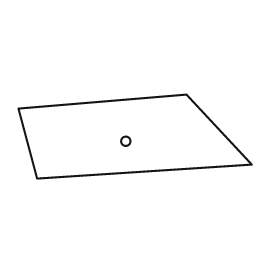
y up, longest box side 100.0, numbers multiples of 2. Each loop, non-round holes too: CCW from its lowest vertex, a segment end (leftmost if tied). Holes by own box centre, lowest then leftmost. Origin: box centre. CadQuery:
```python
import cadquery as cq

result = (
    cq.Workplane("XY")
    .moveTo(-42.0, -18.0)
    .lineTo(50.0, -12.0)
    .lineTo(22.0, 18.0)
    .lineTo(-50.0, 12.0)
    .close()
    .moveTo(-4.0, -2.0)
    .circle(2.0)
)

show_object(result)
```